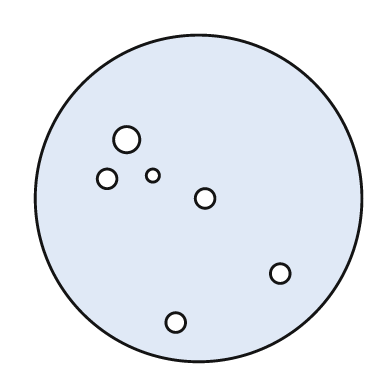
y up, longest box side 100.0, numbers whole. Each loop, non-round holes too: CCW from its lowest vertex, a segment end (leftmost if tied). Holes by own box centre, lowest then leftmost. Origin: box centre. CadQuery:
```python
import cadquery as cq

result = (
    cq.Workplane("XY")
    .moveTo(0.0, 0.0)
    .circle(50.0)
    .moveTo(-7.0, -38.0)
    .circle(3.0)
    .moveTo(25.0, -23.0)
    .circle(3.0)
    .moveTo(2.0, 0.0)
    .circle(3.0)
    .moveTo(-28.0, 6.0)
    .circle(3.0)
    .moveTo(-14.0, 7.0)
    .circle(2.0)
    .moveTo(-22.0, 18.0)
    .circle(4.0)
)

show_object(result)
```